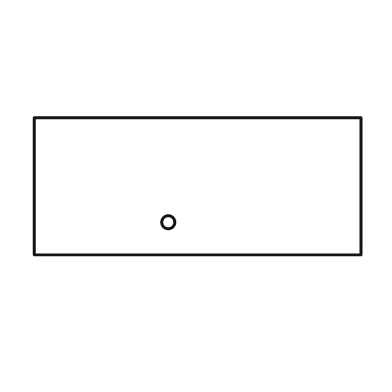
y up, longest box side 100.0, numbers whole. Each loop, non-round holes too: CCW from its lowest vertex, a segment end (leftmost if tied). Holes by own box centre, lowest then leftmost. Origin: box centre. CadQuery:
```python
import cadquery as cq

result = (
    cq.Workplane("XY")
    .moveTo(-50.0, -21.0)
    .lineTo(50.0, -21.0)
    .lineTo(50.0, 21.0)
    .lineTo(-50.0, 21.0)
    .close()
    .moveTo(-9.0, -11.0)
    .circle(2.0)
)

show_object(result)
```